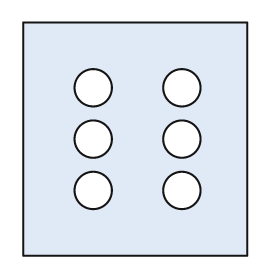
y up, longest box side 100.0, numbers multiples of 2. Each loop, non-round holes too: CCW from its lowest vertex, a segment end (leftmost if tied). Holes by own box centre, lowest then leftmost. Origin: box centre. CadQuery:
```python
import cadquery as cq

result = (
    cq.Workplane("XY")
    .moveTo(-48.0, -50.0)
    .lineTo(48.0, -50.0)
    .lineTo(48.0, 50.0)
    .lineTo(-48.0, 50.0)
    .close()
    .moveTo(-18.0, -22.0)
    .circle(8.0)
    .moveTo(20.0, -22.0)
    .circle(8.0)
    .moveTo(-18.0, 0.0)
    .circle(8.0)
    .moveTo(20.0, 0.0)
    .circle(8.0)
    .moveTo(-18.0, 22.0)
    .circle(8.0)
    .moveTo(20.0, 22.0)
    .circle(8.0)
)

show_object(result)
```